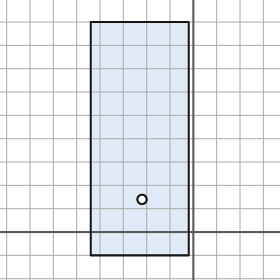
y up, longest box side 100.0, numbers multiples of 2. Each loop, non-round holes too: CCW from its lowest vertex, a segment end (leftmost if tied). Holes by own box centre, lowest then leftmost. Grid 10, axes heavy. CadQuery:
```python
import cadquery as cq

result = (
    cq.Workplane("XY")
    .moveTo(-44.0, -10.0)
    .lineTo(-2.0, -10.0)
    .lineTo(-2.0, 90.0)
    .lineTo(-44.0, 90.0)
    .close()
    .moveTo(-22.0, 14.0)
    .circle(2.0)
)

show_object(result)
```